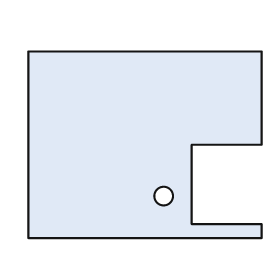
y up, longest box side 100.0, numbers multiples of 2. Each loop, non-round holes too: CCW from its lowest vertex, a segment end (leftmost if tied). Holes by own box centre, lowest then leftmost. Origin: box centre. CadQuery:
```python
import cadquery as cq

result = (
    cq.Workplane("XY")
    .moveTo(-50.0, -40.0)
    .lineTo(50.0, -40.0)
    .lineTo(50.0, -34.0)
    .lineTo(20.0, -34.0)
    .lineTo(20.0, 0.0)
    .lineTo(50.0, 0.0)
    .lineTo(50.0, 40.0)
    .lineTo(-50.0, 40.0)
    .close()
    .moveTo(8.0, -22.0)
    .circle(4.0)
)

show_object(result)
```